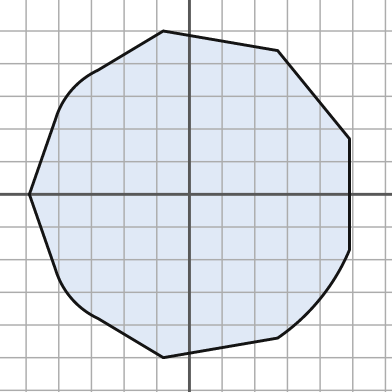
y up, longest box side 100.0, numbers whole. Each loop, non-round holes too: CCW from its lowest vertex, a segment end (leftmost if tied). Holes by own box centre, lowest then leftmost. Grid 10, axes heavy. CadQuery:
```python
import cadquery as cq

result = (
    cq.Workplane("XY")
    .moveTo(-8.0, -50.0)
    .lineTo(27.0, -44.0)
    .threePointArc((40.0, -32.0), (49.0, -17.0))
    .lineTo(49.0, 17.0)
    .lineTo(27.0, 44.0)
    .lineTo(-8.0, 50.0)
    .lineTo(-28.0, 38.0)
    .threePointArc((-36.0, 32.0), (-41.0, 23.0))
    .lineTo(-49.0, 0.0)
    .lineTo(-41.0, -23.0)
    .threePointArc((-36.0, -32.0), (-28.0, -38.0))
    .close()
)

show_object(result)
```